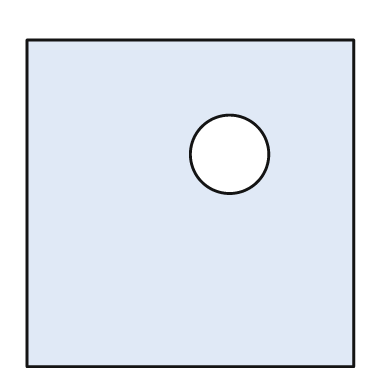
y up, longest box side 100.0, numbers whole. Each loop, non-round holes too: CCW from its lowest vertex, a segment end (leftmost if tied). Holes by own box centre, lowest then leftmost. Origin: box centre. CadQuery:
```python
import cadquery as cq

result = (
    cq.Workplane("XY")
    .moveTo(-50.0, -50.0)
    .lineTo(50.0, -50.0)
    .lineTo(50.0, 50.0)
    .lineTo(-50.0, 50.0)
    .close()
    .moveTo(12.0, 15.0)
    .circle(12.0)
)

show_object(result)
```